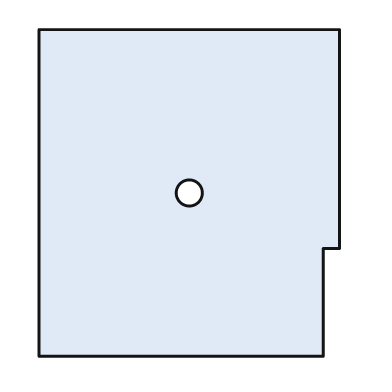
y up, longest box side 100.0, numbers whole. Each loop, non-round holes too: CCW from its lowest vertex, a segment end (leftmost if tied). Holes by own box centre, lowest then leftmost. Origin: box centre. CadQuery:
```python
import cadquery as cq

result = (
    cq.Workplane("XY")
    .moveTo(-46.0, -50.0)
    .lineTo(41.0, -50.0)
    .lineTo(41.0, -17.0)
    .lineTo(46.0, -17.0)
    .lineTo(46.0, 50.0)
    .lineTo(-46.0, 50.0)
    .close()
    .moveTo(0.0, 0.0)
    .circle(4.0)
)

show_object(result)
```